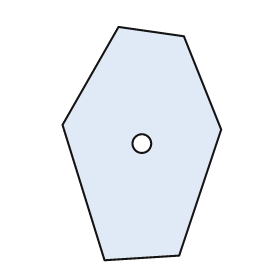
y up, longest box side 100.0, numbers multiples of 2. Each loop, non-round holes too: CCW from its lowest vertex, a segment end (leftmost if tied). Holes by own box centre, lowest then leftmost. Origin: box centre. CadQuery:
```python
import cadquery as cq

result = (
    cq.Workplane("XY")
    .moveTo(-16.0, -50.0)
    .lineTo(16.0, -48.0)
    .lineTo(34.0, 6.0)
    .lineTo(18.0, 46.0)
    .lineTo(-10.0, 50.0)
    .lineTo(-34.0, 8.0)
    .close()
    .moveTo(0.0, 0.0)
    .circle(4.0)
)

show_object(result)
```